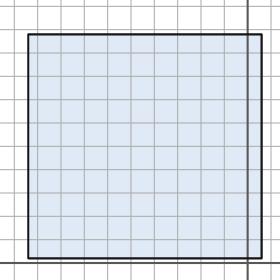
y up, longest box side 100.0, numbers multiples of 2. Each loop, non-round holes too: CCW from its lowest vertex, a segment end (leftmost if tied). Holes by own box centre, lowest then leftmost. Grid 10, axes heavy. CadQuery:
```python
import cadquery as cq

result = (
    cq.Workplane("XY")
    .moveTo(-94.0, 2.0)
    .lineTo(6.0, 2.0)
    .lineTo(6.0, 98.0)
    .lineTo(-94.0, 98.0)
    .close()
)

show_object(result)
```